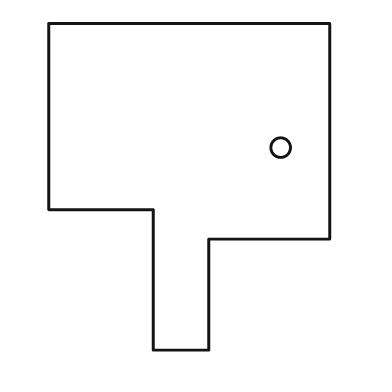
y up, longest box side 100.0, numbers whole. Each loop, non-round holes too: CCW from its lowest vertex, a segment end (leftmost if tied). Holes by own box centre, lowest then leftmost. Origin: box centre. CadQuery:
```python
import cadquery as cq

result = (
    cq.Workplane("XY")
    .moveTo(-11.0, -50.0)
    .lineTo(6.0, -50.0)
    .lineTo(6.0, -16.0)
    .lineTo(43.0, -16.0)
    .lineTo(43.0, 50.0)
    .lineTo(-43.0, 50.0)
    .lineTo(-43.0, -7.0)
    .lineTo(-11.0, -7.0)
    .close()
    .moveTo(28.0, 12.0)
    .circle(3.0)
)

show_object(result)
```